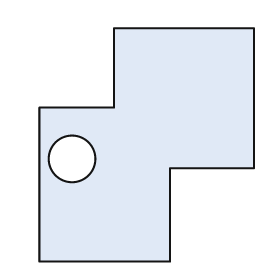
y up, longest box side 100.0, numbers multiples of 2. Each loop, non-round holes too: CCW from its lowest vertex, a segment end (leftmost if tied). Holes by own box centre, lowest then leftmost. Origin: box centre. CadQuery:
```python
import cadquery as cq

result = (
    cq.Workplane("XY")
    .moveTo(-46.0, -50.0)
    .lineTo(10.0, -50.0)
    .lineTo(10.0, -10.0)
    .lineTo(46.0, -10.0)
    .lineTo(46.0, 50.0)
    .lineTo(-14.0, 50.0)
    .lineTo(-14.0, 16.0)
    .lineTo(-46.0, 16.0)
    .close()
    .moveTo(-32.0, -6.0)
    .circle(10.0)
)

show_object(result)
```